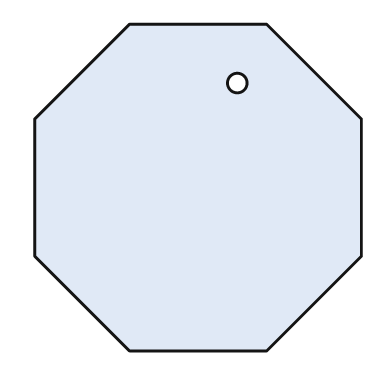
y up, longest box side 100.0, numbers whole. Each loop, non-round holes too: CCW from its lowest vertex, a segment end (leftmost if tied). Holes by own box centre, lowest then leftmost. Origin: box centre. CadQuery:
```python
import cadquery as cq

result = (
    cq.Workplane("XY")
    .moveTo(-21.0, -50.0)
    .lineTo(21.0, -50.0)
    .lineTo(50.0, -21.0)
    .lineTo(50.0, 21.0)
    .lineTo(21.0, 50.0)
    .lineTo(-21.0, 50.0)
    .lineTo(-50.0, 21.0)
    .lineTo(-50.0, -21.0)
    .close()
    .moveTo(12.0, 32.0)
    .circle(3.0)
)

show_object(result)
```